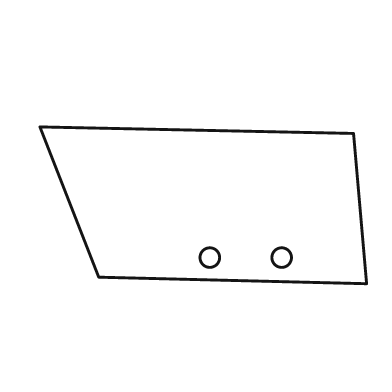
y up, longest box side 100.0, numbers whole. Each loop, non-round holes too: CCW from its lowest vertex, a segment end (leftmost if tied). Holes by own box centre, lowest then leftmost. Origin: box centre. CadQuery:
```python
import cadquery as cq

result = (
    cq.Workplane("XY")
    .moveTo(50.0, -24.0)
    .lineTo(46.0, 22.0)
    .lineTo(-50.0, 24.0)
    .lineTo(-32.0, -22.0)
    .close()
    .moveTo(2.0, -16.0)
    .circle(3.0)
    .moveTo(24.0, -16.0)
    .circle(3.0)
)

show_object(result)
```